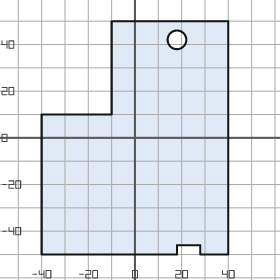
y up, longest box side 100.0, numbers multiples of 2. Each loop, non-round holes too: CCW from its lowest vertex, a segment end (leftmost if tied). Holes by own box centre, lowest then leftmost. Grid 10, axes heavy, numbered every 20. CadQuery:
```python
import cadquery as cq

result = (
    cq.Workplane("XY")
    .moveTo(-40.0, -50.0)
    .lineTo(18.0, -50.0)
    .lineTo(18.0, -46.0)
    .lineTo(28.0, -46.0)
    .lineTo(28.0, -50.0)
    .lineTo(40.0, -50.0)
    .lineTo(40.0, 50.0)
    .lineTo(-10.0, 50.0)
    .lineTo(-10.0, 10.0)
    .lineTo(-40.0, 10.0)
    .close()
    .moveTo(18.0, 42.0)
    .circle(4.0)
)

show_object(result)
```